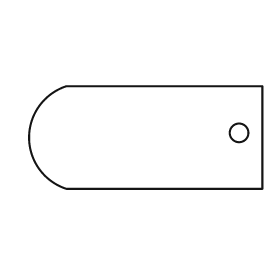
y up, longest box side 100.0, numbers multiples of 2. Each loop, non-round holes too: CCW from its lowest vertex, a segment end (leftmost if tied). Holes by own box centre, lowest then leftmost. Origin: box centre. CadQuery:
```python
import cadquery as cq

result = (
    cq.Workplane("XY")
    .moveTo(-34.0, -22.0)
    .lineTo(50.0, -22.0)
    .lineTo(50.0, 22.0)
    .lineTo(-34.0, 22.0)
    .threePointArc((-50.0, 0.0), (-34.0, -22.0))
    .close()
    .moveTo(40.0, 2.0)
    .circle(4.0)
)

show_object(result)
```